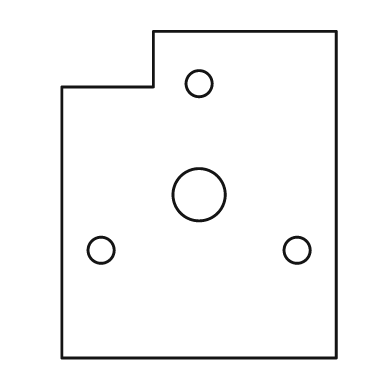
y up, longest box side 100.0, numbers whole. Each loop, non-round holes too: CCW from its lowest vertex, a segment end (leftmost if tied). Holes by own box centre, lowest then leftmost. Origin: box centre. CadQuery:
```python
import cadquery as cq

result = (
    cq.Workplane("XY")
    .moveTo(-42.0, -50.0)
    .lineTo(42.0, -50.0)
    .lineTo(42.0, 50.0)
    .lineTo(-14.0, 50.0)
    .lineTo(-14.0, 33.0)
    .lineTo(-42.0, 33.0)
    .close()
    .moveTo(-30.0, -17.0)
    .circle(4.0)
    .moveTo(30.0, -17.0)
    .circle(4.0)
    .moveTo(0.0, 0.0)
    .circle(8.0)
    .moveTo(0.0, 34.0)
    .circle(4.0)
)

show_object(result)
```